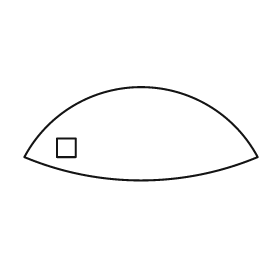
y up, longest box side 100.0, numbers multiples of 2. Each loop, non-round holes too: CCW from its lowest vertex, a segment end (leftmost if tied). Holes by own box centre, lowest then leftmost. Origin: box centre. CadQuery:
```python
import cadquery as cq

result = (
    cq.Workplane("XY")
    .moveTo(-50.0, -10.0)
    .threePointArc((0.0, -20.0), (50.0, -10.0))
    .threePointArc((0.0, 20.0), (-50.0, -10.0))
    .close()
    .moveTo(-36.0, -10.0)
    .lineTo(-28.0, -10.0)
    .lineTo(-28.0, -2.0)
    .lineTo(-36.0, -2.0)
    .close()
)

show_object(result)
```